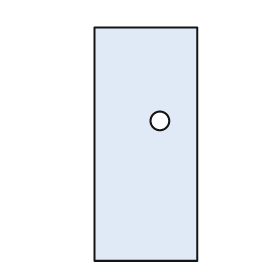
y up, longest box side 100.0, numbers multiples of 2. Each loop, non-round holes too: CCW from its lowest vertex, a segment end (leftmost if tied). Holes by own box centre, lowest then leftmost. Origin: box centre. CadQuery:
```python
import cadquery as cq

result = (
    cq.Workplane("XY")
    .moveTo(-22.0, -50.0)
    .lineTo(22.0, -50.0)
    .lineTo(22.0, 50.0)
    .lineTo(-22.0, 50.0)
    .close()
    .moveTo(6.0, 10.0)
    .circle(4.0)
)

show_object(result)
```